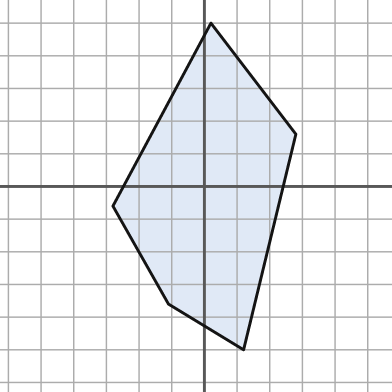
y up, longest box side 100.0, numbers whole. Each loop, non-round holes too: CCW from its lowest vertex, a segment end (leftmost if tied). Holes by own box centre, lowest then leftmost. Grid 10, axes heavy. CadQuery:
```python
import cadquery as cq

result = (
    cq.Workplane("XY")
    .moveTo(12.0, -50.0)
    .lineTo(28.0, 16.0)
    .lineTo(2.0, 50.0)
    .lineTo(-28.0, -6.0)
    .lineTo(-11.0, -36.0)
    .close()
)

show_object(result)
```